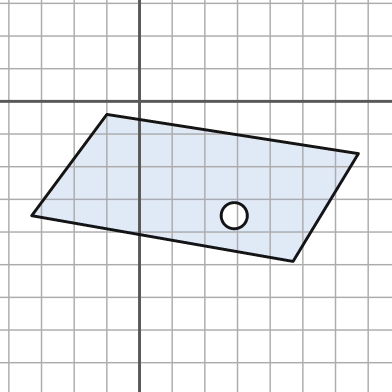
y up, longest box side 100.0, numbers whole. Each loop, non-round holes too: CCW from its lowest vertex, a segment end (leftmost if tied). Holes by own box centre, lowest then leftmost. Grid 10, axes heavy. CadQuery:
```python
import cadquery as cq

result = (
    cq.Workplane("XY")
    .moveTo(47.0, -49.0)
    .lineTo(67.0, -16.0)
    .lineTo(-10.0, -4.0)
    .lineTo(-33.0, -35.0)
    .close()
    .moveTo(29.0, -35.0)
    .circle(4.0)
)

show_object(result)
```